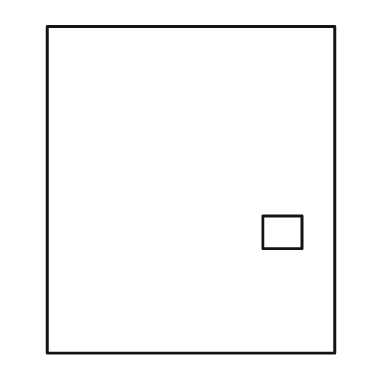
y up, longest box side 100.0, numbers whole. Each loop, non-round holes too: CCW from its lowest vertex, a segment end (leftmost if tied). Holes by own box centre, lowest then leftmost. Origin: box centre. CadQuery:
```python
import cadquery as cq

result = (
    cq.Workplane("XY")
    .moveTo(-44.0, -50.0)
    .lineTo(44.0, -50.0)
    .lineTo(44.0, 50.0)
    .lineTo(-44.0, 50.0)
    .close()
    .moveTo(22.0, -18.0)
    .lineTo(34.0, -18.0)
    .lineTo(34.0, -8.0)
    .lineTo(22.0, -8.0)
    .close()
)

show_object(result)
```